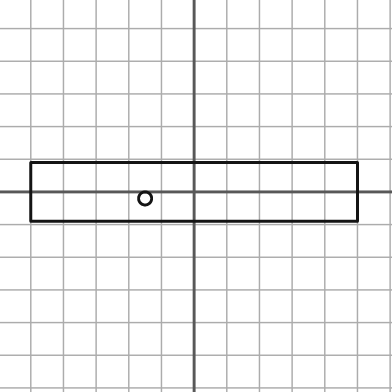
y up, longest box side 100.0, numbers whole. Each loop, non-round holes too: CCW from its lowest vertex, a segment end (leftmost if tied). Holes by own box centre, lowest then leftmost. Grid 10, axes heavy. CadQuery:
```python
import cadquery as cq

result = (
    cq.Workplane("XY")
    .moveTo(-50.0, -9.0)
    .lineTo(50.0, -9.0)
    .lineTo(50.0, 9.0)
    .lineTo(-50.0, 9.0)
    .close()
    .moveTo(-15.0, -2.0)
    .circle(2.0)
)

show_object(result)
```